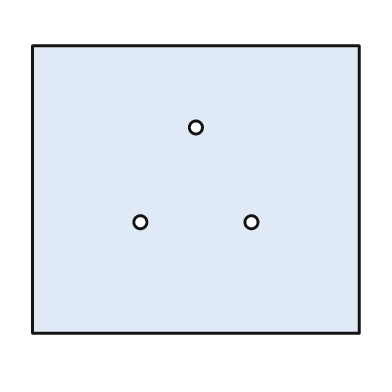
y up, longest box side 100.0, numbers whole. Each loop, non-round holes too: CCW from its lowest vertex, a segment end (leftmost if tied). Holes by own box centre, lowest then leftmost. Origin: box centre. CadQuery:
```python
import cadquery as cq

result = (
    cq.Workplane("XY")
    .moveTo(-50.0, -44.0)
    .lineTo(50.0, -44.0)
    .lineTo(50.0, 44.0)
    .lineTo(-50.0, 44.0)
    .close()
    .moveTo(-17.0, -10.0)
    .circle(2.0)
    .moveTo(17.0, -10.0)
    .circle(2.0)
    .moveTo(0.0, 19.0)
    .circle(2.0)
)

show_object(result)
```